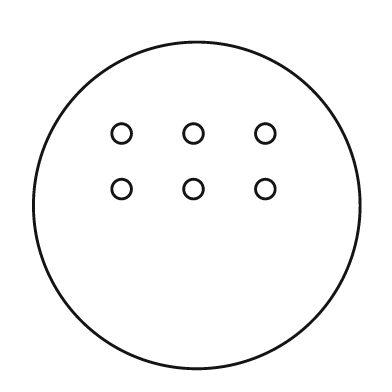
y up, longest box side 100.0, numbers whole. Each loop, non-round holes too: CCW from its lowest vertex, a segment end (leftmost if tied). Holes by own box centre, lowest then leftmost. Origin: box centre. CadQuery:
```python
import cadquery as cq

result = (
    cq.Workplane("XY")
    .moveTo(0.0, 0.0)
    .circle(50.0)
    .moveTo(-23.0, 5.0)
    .circle(3.0)
    .moveTo(-1.0, 5.0)
    .circle(3.0)
    .moveTo(21.0, 5.0)
    .circle(3.0)
    .moveTo(-23.0, 22.0)
    .circle(3.0)
    .moveTo(-1.0, 22.0)
    .circle(3.0)
    .moveTo(21.0, 22.0)
    .circle(3.0)
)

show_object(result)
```